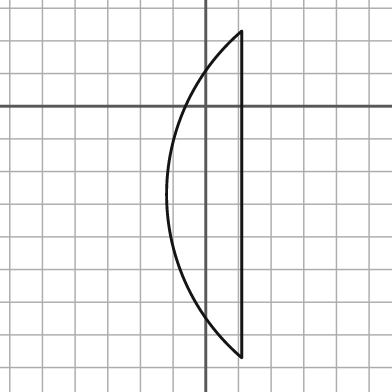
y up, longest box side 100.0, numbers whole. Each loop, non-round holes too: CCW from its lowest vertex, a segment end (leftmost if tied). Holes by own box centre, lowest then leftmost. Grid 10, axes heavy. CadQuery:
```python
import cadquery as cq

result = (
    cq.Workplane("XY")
    .moveTo(11.0, -77.0)
    .lineTo(11.0, 23.0)
    .threePointArc((-12.0, -27.0), (11.0, -77.0))
    .close()
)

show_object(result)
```